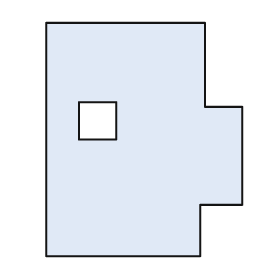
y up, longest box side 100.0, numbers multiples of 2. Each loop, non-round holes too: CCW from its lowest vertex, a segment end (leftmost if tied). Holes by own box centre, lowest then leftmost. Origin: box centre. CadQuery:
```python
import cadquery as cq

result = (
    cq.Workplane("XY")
    .moveTo(-42.0, -50.0)
    .lineTo(24.0, -50.0)
    .lineTo(24.0, -28.0)
    .lineTo(42.0, -28.0)
    .lineTo(42.0, 14.0)
    .lineTo(26.0, 14.0)
    .lineTo(26.0, 50.0)
    .lineTo(-42.0, 50.0)
    .close()
    .moveTo(-28.0, 0.0)
    .lineTo(-12.0, 0.0)
    .lineTo(-12.0, 16.0)
    .lineTo(-28.0, 16.0)
    .close()
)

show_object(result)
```